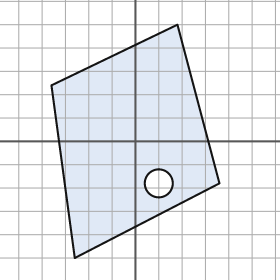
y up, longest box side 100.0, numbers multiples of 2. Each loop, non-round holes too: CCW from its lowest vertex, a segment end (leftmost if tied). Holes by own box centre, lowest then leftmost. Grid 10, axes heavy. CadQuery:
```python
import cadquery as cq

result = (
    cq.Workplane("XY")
    .moveTo(-26.0, -50.0)
    .lineTo(36.0, -18.0)
    .lineTo(18.0, 50.0)
    .lineTo(-36.0, 24.0)
    .close()
    .moveTo(10.0, -18.0)
    .circle(6.0)
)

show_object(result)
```